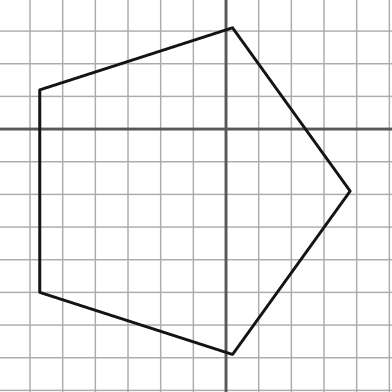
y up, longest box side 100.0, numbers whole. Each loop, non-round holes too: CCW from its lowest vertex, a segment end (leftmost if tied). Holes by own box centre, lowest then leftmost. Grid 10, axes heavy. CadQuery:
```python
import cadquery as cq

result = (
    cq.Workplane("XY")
    .moveTo(2.0, -69.0)
    .lineTo(38.0, -19.0)
    .lineTo(2.0, 31.0)
    .lineTo(-57.0, 12.0)
    .lineTo(-57.0, -50.0)
    .close()
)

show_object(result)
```